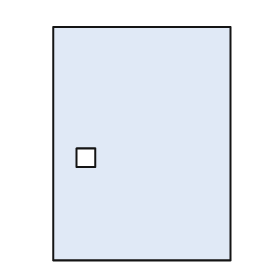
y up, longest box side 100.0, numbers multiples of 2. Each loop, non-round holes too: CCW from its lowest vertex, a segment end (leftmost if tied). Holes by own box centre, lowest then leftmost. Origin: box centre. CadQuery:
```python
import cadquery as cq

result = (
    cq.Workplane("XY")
    .moveTo(-38.0, -50.0)
    .lineTo(38.0, -50.0)
    .lineTo(38.0, 50.0)
    .lineTo(-38.0, 50.0)
    .close()
    .moveTo(-28.0, -10.0)
    .lineTo(-20.0, -10.0)
    .lineTo(-20.0, -2.0)
    .lineTo(-28.0, -2.0)
    .close()
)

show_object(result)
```